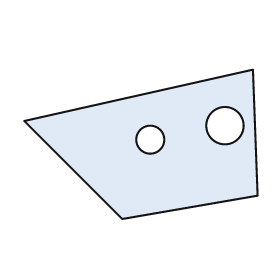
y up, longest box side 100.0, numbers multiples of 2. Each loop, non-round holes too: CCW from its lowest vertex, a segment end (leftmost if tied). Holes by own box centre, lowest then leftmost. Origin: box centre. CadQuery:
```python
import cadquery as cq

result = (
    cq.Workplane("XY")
    .moveTo(-8.0, -32.0)
    .lineTo(50.0, -22.0)
    .lineTo(48.0, 32.0)
    .lineTo(-50.0, 10.0)
    .close()
    .moveTo(4.0, 2.0)
    .circle(6.0)
    .moveTo(36.0, 8.0)
    .circle(8.0)
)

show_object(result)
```